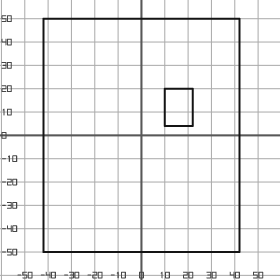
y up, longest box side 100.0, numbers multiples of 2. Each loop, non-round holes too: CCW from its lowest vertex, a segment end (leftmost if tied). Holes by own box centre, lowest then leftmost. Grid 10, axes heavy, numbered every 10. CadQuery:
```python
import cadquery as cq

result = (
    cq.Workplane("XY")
    .moveTo(-42.0, -50.0)
    .lineTo(42.0, -50.0)
    .lineTo(42.0, 50.0)
    .lineTo(-42.0, 50.0)
    .close()
    .moveTo(10.0, 4.0)
    .lineTo(22.0, 4.0)
    .lineTo(22.0, 20.0)
    .lineTo(10.0, 20.0)
    .close()
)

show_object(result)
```